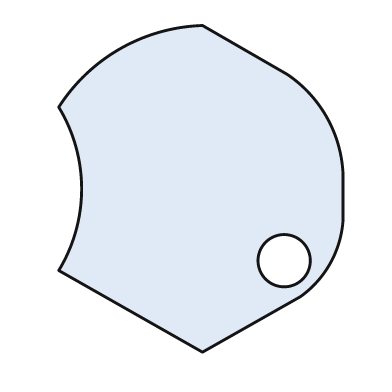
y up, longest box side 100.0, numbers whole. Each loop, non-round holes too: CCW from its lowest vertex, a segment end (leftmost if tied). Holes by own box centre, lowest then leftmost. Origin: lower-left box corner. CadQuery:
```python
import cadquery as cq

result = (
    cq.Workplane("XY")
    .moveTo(44.0, 0.0)
    .lineTo(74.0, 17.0)
    .threePointArc((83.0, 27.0), (87.0, 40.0))
    .lineTo(87.0, 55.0)
    .threePointArc((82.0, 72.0), (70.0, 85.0))
    .lineTo(44.0, 100.0)
    .threePointArc((19.0, 93.0), (0.0, 75.0))
    .threePointArc((7.0, 50.0), (0.0, 25.0))
    .close()
    .moveTo(69.0, 28.0)
    .circle(8.0)
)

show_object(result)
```